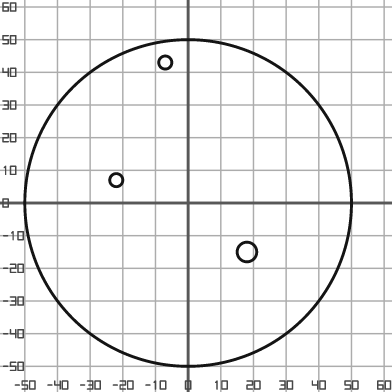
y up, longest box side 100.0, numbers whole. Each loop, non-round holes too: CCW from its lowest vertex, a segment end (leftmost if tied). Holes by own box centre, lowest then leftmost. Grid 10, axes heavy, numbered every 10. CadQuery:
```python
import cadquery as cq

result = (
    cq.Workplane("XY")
    .moveTo(0.0, 0.0)
    .circle(50.0)
    .moveTo(18.0, -15.0)
    .circle(3.0)
    .moveTo(-22.0, 7.0)
    .circle(2.0)
    .moveTo(-7.0, 43.0)
    .circle(2.0)
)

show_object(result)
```